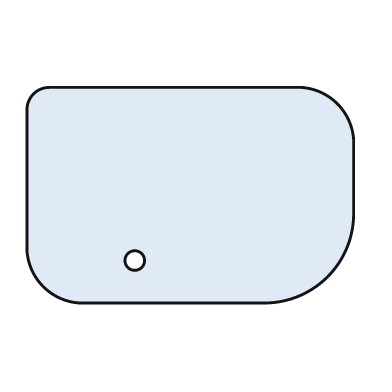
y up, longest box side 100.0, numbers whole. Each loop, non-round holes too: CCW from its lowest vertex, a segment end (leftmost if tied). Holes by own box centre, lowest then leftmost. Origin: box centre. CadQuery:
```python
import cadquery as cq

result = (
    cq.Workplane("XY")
    .moveTo(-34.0, -33.0)
    .lineTo(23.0, -33.0)
    .threePointArc((42.0, -25.0), (50.0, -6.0))
    .lineTo(50.0, 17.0)
    .threePointArc((45.0, 28.0), (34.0, 33.0))
    .lineTo(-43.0, 33.0)
    .threePointArc((-48.0, 31.0), (-50.0, 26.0))
    .lineTo(-50.0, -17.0)
    .threePointArc((-45.0, -28.0), (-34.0, -33.0))
    .close()
    .moveTo(-17.0, -20.0)
    .circle(3.0)
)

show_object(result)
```